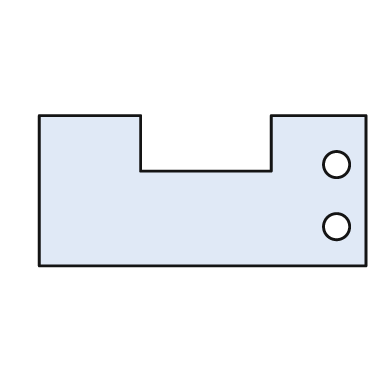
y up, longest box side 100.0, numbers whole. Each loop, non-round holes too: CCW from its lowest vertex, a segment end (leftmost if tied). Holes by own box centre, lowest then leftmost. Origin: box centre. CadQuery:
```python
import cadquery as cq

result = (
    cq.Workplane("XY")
    .moveTo(-50.0, -23.0)
    .lineTo(50.0, -23.0)
    .lineTo(50.0, 23.0)
    .lineTo(21.0, 23.0)
    .lineTo(21.0, 6.0)
    .lineTo(-19.0, 6.0)
    .lineTo(-19.0, 23.0)
    .lineTo(-50.0, 23.0)
    .close()
    .moveTo(41.0, -11.0)
    .circle(4.0)
    .moveTo(41.0, 8.0)
    .circle(4.0)
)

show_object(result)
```